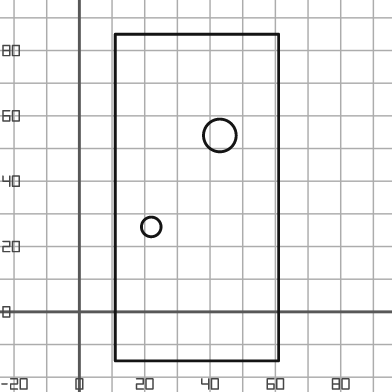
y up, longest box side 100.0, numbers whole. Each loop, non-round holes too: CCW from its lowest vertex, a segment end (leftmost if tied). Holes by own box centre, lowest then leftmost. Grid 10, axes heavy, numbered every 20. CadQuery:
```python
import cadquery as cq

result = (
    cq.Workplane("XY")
    .moveTo(11.0, -15.0)
    .lineTo(61.0, -15.0)
    .lineTo(61.0, 85.0)
    .lineTo(11.0, 85.0)
    .close()
    .moveTo(22.0, 26.0)
    .circle(3.0)
    .moveTo(43.0, 54.0)
    .circle(5.0)
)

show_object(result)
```